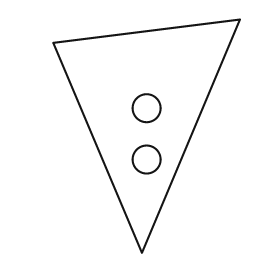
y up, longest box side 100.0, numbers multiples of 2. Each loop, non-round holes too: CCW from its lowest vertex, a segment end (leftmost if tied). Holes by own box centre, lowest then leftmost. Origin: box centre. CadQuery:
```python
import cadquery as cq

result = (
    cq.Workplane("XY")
    .moveTo(-2.0, -50.0)
    .lineTo(40.0, 50.0)
    .lineTo(-40.0, 40.0)
    .close()
    .moveTo(0.0, -10.0)
    .circle(6.0)
    .moveTo(0.0, 12.0)
    .circle(6.0)
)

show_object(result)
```